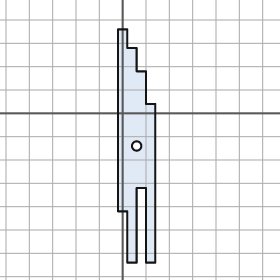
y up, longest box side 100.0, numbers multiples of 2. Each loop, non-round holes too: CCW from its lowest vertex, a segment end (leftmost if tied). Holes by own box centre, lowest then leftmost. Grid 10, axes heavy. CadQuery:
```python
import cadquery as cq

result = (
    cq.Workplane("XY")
    .moveTo(2.0, -64.0)
    .lineTo(6.0, -64.0)
    .lineTo(6.0, -32.0)
    .lineTo(10.0, -32.0)
    .lineTo(10.0, -64.0)
    .lineTo(14.0, -64.0)
    .lineTo(14.0, 4.0)
    .lineTo(10.0, 4.0)
    .lineTo(10.0, 18.0)
    .lineTo(6.0, 18.0)
    .lineTo(6.0, 28.0)
    .lineTo(2.0, 28.0)
    .lineTo(2.0, 36.0)
    .lineTo(-2.0, 36.0)
    .lineTo(-2.0, -42.0)
    .lineTo(2.0, -42.0)
    .close()
    .moveTo(6.0, -14.0)
    .circle(2.0)
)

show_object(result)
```